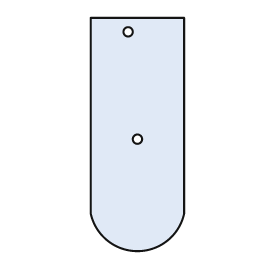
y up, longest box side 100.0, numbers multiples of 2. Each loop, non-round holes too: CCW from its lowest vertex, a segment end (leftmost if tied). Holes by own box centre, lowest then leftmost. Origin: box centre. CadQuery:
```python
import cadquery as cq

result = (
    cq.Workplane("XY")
    .moveTo(-20.0, -34.0)
    .threePointArc((0.0, -50.0), (20.0, -34.0))
    .lineTo(20.0, 50.0)
    .lineTo(-20.0, 50.0)
    .close()
    .moveTo(0.0, -2.0)
    .circle(2.0)
    .moveTo(-4.0, 44.0)
    .circle(2.0)
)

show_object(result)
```